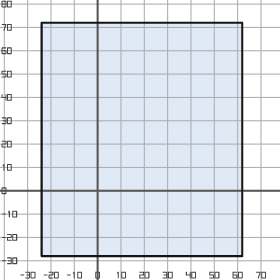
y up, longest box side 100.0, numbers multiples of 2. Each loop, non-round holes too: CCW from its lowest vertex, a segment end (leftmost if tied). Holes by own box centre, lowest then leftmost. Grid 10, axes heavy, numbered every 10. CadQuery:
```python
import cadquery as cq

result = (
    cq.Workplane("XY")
    .moveTo(-24.0, -28.0)
    .lineTo(62.0, -28.0)
    .lineTo(62.0, 72.0)
    .lineTo(-24.0, 72.0)
    .close()
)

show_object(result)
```